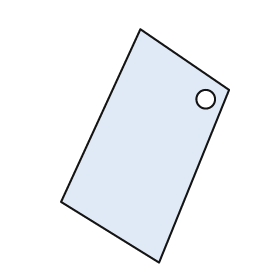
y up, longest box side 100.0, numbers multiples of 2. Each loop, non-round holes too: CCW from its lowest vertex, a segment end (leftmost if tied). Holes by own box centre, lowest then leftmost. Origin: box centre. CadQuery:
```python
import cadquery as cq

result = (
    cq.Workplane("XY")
    .moveTo(6.0, -50.0)
    .lineTo(36.0, 24.0)
    .lineTo(-2.0, 50.0)
    .lineTo(-36.0, -24.0)
    .close()
    .moveTo(26.0, 20.0)
    .circle(4.0)
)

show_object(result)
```